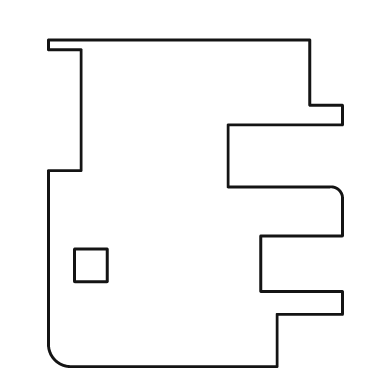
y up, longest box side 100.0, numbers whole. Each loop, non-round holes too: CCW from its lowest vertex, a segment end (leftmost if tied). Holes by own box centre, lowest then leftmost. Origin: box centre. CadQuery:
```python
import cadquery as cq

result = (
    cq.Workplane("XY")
    .moveTo(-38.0, -50.0)
    .lineTo(25.0, -50.0)
    .lineTo(25.0, -34.0)
    .lineTo(45.0, -34.0)
    .lineTo(45.0, -27.0)
    .lineTo(20.0, -27.0)
    .lineTo(20.0, -10.0)
    .lineTo(45.0, -10.0)
    .lineTo(45.0, 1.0)
    .threePointArc((44.0, 4.0), (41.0, 5.0))
    .lineTo(10.0, 5.0)
    .lineTo(10.0, 24.0)
    .lineTo(45.0, 24.0)
    .lineTo(45.0, 30.0)
    .lineTo(35.0, 30.0)
    .lineTo(35.0, 50.0)
    .lineTo(-45.0, 50.0)
    .lineTo(-45.0, 47.0)
    .lineTo(-35.0, 47.0)
    .lineTo(-35.0, 10.0)
    .lineTo(-45.0, 10.0)
    .lineTo(-45.0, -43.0)
    .threePointArc((-43.0, -48.0), (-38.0, -50.0))
    .close()
    .moveTo(-37.0, -24.0)
    .lineTo(-27.0, -24.0)
    .lineTo(-27.0, -14.0)
    .lineTo(-37.0, -14.0)
    .close()
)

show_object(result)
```